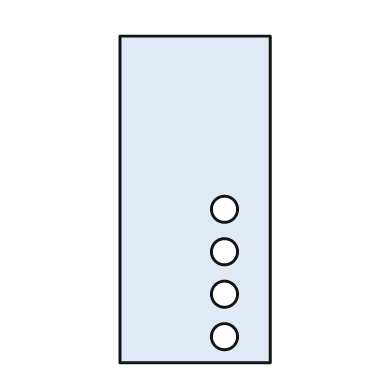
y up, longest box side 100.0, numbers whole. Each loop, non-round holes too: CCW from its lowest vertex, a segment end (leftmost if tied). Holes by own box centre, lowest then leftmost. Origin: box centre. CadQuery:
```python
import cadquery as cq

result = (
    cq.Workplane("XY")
    .moveTo(-23.0, -50.0)
    .lineTo(23.0, -50.0)
    .lineTo(23.0, 50.0)
    .lineTo(-23.0, 50.0)
    .close()
    .moveTo(9.0, -42.0)
    .circle(4.0)
    .moveTo(9.0, -29.0)
    .circle(4.0)
    .moveTo(9.0, -16.0)
    .circle(4.0)
    .moveTo(9.0, -3.0)
    .circle(4.0)
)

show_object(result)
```